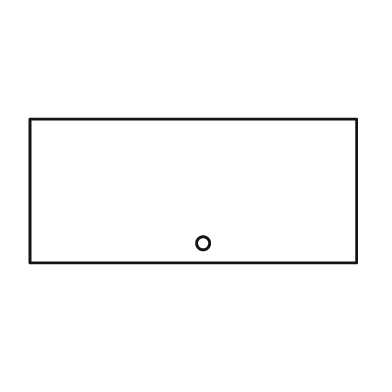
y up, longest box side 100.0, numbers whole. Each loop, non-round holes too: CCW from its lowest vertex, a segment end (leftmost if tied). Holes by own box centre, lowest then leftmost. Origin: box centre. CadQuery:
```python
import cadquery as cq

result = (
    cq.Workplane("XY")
    .moveTo(-50.0, -22.0)
    .lineTo(50.0, -22.0)
    .lineTo(50.0, 22.0)
    .lineTo(-50.0, 22.0)
    .close()
    .moveTo(3.0, -16.0)
    .circle(2.0)
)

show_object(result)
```